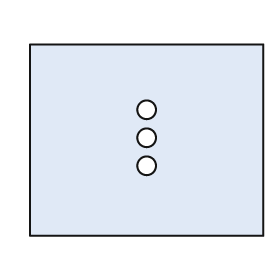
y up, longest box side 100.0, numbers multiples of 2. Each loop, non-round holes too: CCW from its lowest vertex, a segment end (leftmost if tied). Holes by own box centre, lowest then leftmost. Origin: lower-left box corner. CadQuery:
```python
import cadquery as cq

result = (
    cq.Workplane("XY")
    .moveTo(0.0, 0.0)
    .lineTo(100.0, 0.0)
    .lineTo(100.0, 82.0)
    .lineTo(0.0, 82.0)
    .close()
    .moveTo(50.0, 30.0)
    .circle(4.0)
    .moveTo(50.0, 42.0)
    .circle(4.0)
    .moveTo(50.0, 54.0)
    .circle(4.0)
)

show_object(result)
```